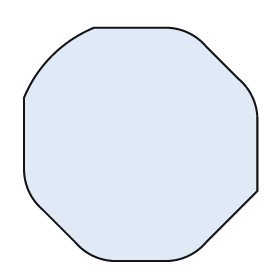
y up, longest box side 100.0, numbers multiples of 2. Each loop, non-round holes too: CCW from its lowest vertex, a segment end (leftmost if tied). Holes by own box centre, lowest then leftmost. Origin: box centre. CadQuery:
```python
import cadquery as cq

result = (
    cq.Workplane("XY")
    .moveTo(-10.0, -50.0)
    .lineTo(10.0, -50.0)
    .threePointArc((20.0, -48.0), (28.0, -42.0))
    .lineTo(50.0, -20.0)
    .lineTo(50.0, 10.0)
    .threePointArc((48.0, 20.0), (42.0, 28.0))
    .lineTo(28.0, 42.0)
    .threePointArc((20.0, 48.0), (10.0, 50.0))
    .lineTo(-20.0, 50.0)
    .threePointArc((-38.0, 38.0), (-50.0, 20.0))
    .lineTo(-50.0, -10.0)
    .threePointArc((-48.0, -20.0), (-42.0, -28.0))
    .lineTo(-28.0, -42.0)
    .threePointArc((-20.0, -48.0), (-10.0, -50.0))
    .close()
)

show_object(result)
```